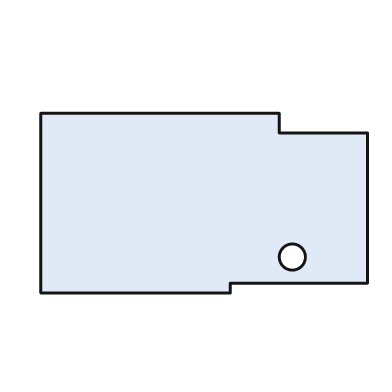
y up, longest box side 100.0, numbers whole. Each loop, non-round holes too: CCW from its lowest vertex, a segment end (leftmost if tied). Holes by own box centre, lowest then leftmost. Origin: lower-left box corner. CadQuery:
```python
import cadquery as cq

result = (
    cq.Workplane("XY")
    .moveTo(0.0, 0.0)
    .lineTo(58.0, 0.0)
    .lineTo(58.0, 3.0)
    .lineTo(100.0, 3.0)
    .lineTo(100.0, 49.0)
    .lineTo(73.0, 49.0)
    .lineTo(73.0, 55.0)
    .lineTo(0.0, 55.0)
    .close()
    .moveTo(77.0, 11.0)
    .circle(4.0)
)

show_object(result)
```